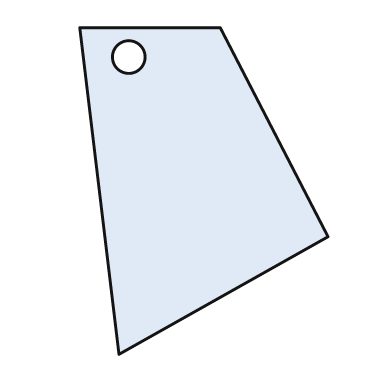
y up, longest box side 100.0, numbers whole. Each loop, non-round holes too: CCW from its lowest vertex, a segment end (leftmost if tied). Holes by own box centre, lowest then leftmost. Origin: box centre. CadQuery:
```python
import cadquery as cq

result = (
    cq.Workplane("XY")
    .moveTo(-26.0, -50.0)
    .lineTo(38.0, -14.0)
    .lineTo(5.0, 50.0)
    .lineTo(-38.0, 50.0)
    .close()
    .moveTo(-23.0, 41.0)
    .circle(5.0)
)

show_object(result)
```